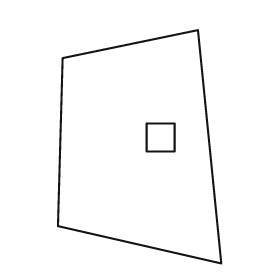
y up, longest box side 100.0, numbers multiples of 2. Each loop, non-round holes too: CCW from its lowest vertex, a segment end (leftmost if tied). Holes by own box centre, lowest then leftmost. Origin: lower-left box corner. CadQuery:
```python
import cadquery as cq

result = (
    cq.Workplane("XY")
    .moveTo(70.0, 0.0)
    .lineTo(60.0, 100.0)
    .lineTo(2.0, 88.0)
    .lineTo(0.0, 16.0)
    .close()
    .moveTo(38.0, 48.0)
    .lineTo(50.0, 48.0)
    .lineTo(50.0, 60.0)
    .lineTo(38.0, 60.0)
    .close()
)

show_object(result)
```